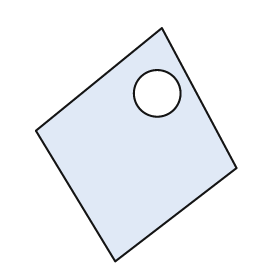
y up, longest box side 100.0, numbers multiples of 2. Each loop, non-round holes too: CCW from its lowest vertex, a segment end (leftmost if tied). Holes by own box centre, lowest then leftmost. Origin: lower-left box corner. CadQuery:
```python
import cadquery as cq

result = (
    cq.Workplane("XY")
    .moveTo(34.0, 0.0)
    .lineTo(86.0, 40.0)
    .lineTo(54.0, 100.0)
    .lineTo(0.0, 56.0)
    .close()
    .moveTo(52.0, 72.0)
    .circle(10.0)
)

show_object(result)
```